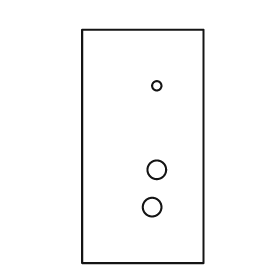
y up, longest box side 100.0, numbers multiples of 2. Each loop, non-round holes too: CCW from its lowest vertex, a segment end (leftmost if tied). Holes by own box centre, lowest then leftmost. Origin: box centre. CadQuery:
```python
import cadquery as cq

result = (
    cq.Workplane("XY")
    .moveTo(-26.0, -50.0)
    .lineTo(26.0, -50.0)
    .lineTo(26.0, 50.0)
    .lineTo(-26.0, 50.0)
    .close()
    .moveTo(4.0, -26.0)
    .circle(4.0)
    .moveTo(6.0, -10.0)
    .circle(4.0)
    .moveTo(6.0, 26.0)
    .circle(2.0)
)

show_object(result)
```